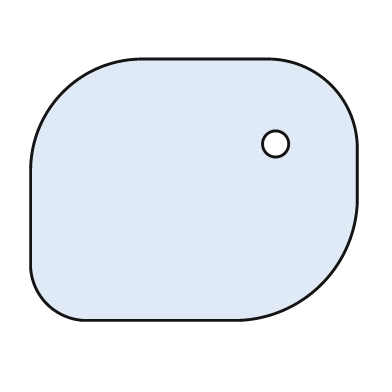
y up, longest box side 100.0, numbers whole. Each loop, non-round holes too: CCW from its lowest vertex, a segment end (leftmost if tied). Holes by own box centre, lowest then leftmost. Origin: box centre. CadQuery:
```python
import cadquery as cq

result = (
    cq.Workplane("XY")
    .moveTo(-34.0, -40.0)
    .lineTo(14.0, -40.0)
    .threePointArc((39.0, -29.0), (50.0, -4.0))
    .lineTo(50.0, 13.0)
    .threePointArc((42.0, 32.0), (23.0, 40.0))
    .lineTo(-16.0, 40.0)
    .threePointArc((-40.0, 30.0), (-50.0, 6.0))
    .lineTo(-50.0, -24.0)
    .threePointArc((-45.0, -35.0), (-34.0, -40.0))
    .close()
    .moveTo(25.0, 14.0)
    .circle(4.0)
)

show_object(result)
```